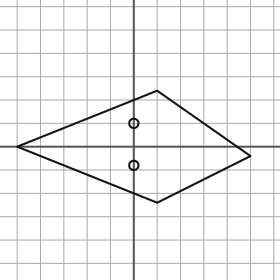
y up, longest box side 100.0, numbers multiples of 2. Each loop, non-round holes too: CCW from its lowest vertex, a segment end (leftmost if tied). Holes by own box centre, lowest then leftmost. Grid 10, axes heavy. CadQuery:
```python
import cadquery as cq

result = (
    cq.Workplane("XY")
    .moveTo(10.0, -24.0)
    .lineTo(50.0, -4.0)
    .lineTo(10.0, 24.0)
    .lineTo(-50.0, 0.0)
    .close()
    .moveTo(0.0, -8.0)
    .circle(2.0)
    .moveTo(0.0, 10.0)
    .circle(2.0)
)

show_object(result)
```